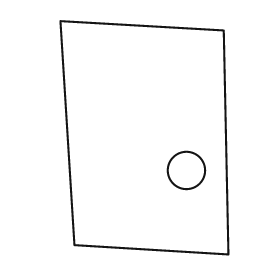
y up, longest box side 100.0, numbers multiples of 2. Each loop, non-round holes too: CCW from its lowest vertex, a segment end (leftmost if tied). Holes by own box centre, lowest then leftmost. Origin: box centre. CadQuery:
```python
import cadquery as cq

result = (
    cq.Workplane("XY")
    .moveTo(36.0, -50.0)
    .lineTo(34.0, 46.0)
    .lineTo(-36.0, 50.0)
    .lineTo(-30.0, -46.0)
    .close()
    .moveTo(18.0, -14.0)
    .circle(8.0)
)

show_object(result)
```